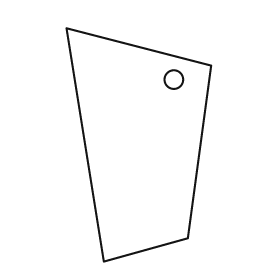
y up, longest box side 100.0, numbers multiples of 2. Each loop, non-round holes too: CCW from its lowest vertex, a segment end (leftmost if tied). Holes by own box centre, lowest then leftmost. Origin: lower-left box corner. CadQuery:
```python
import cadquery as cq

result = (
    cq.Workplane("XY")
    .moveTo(16.0, 0.0)
    .lineTo(52.0, 10.0)
    .lineTo(62.0, 84.0)
    .lineTo(0.0, 100.0)
    .close()
    .moveTo(46.0, 78.0)
    .circle(4.0)
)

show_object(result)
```